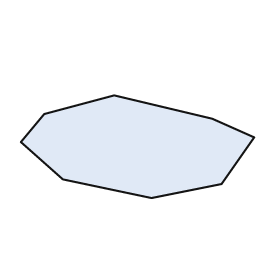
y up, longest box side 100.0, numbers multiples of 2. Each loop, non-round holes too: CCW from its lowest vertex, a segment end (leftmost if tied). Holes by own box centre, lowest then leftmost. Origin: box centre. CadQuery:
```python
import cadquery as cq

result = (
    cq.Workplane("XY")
    .moveTo(6.0, -22.0)
    .lineTo(36.0, -16.0)
    .lineTo(50.0, 4.0)
    .lineTo(32.0, 12.0)
    .lineTo(-10.0, 22.0)
    .lineTo(-40.0, 14.0)
    .lineTo(-50.0, 2.0)
    .lineTo(-32.0, -14.0)
    .close()
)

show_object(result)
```